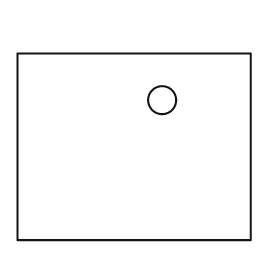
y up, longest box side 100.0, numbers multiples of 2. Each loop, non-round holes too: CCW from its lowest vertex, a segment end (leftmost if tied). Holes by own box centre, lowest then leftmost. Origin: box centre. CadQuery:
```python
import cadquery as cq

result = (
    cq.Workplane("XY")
    .moveTo(-50.0, -40.0)
    .lineTo(50.0, -40.0)
    .lineTo(50.0, 40.0)
    .lineTo(-50.0, 40.0)
    .close()
    .moveTo(12.0, 20.0)
    .circle(6.0)
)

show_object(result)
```